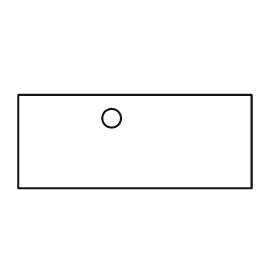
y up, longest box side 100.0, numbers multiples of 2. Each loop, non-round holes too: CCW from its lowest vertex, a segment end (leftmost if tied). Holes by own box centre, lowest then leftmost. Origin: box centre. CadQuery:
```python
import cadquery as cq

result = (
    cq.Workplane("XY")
    .moveTo(-50.0, -20.0)
    .lineTo(50.0, -20.0)
    .lineTo(50.0, 20.0)
    .lineTo(-50.0, 20.0)
    .close()
    .moveTo(-10.0, 10.0)
    .circle(4.0)
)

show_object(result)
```